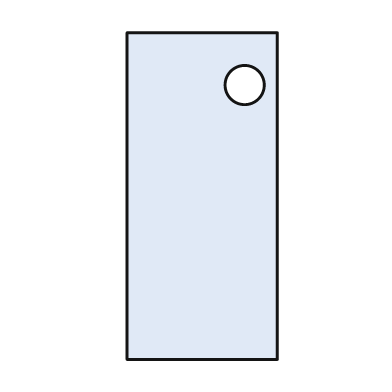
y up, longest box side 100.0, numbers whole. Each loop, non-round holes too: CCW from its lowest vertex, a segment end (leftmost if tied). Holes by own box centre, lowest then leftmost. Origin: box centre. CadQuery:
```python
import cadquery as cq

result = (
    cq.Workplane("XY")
    .moveTo(-23.0, -50.0)
    .lineTo(23.0, -50.0)
    .lineTo(23.0, 50.0)
    .lineTo(-23.0, 50.0)
    .close()
    .moveTo(13.0, 34.0)
    .circle(6.0)
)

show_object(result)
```